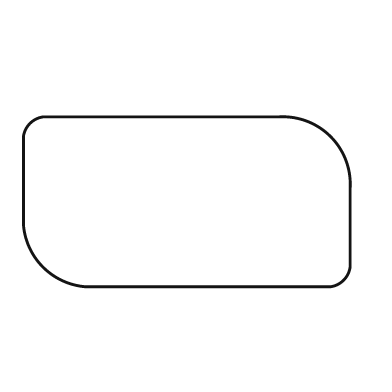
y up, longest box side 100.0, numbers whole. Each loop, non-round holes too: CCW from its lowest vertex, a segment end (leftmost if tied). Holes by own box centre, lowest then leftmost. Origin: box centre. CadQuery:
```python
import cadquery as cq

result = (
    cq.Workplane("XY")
    .moveTo(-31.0, -26.0)
    .lineTo(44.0, -26.0)
    .threePointArc((48.0, -24.0), (50.0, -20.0))
    .lineTo(50.0, 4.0)
    .threePointArc((44.0, 20.0), (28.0, 26.0))
    .lineTo(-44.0, 26.0)
    .threePointArc((-48.0, 24.0), (-50.0, 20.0))
    .lineTo(-50.0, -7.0)
    .threePointArc((-44.0, -20.0), (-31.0, -26.0))
    .close()
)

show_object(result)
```